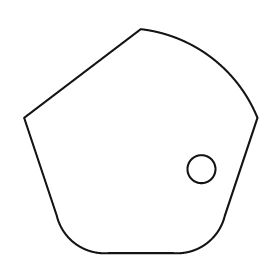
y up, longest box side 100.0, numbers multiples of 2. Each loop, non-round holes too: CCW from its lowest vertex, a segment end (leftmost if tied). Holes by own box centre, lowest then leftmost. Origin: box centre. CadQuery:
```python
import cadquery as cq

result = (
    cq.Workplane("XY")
    .moveTo(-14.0, -48.0)
    .lineTo(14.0, -48.0)
    .threePointArc((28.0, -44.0), (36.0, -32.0))
    .lineTo(50.0, 10.0)
    .threePointArc((30.0, 36.0), (0.0, 48.0))
    .lineTo(-50.0, 10.0)
    .lineTo(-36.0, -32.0)
    .threePointArc((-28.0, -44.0), (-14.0, -48.0))
    .close()
    .moveTo(26.0, -12.0)
    .circle(6.0)
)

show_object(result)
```